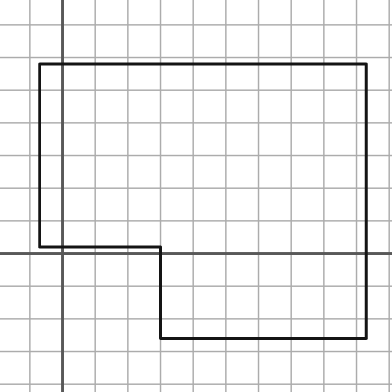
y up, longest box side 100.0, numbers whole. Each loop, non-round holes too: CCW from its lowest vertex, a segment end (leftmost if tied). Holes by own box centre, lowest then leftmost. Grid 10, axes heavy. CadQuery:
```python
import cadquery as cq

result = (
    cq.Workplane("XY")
    .moveTo(30.0, -26.0)
    .lineTo(93.0, -26.0)
    .lineTo(93.0, 58.0)
    .lineTo(-7.0, 58.0)
    .lineTo(-7.0, 2.0)
    .lineTo(30.0, 2.0)
    .close()
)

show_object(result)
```